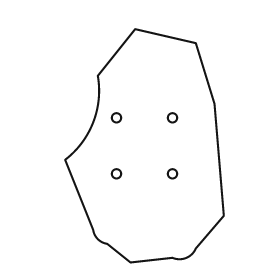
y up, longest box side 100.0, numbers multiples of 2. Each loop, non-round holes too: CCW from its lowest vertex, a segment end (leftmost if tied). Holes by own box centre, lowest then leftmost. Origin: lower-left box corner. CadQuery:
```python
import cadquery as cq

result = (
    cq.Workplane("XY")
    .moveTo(28.0, 0.0)
    .lineTo(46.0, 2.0)
    .threePointArc((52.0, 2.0), (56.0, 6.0))
    .lineTo(68.0, 20.0)
    .lineTo(64.0, 68.0)
    .lineTo(56.0, 94.0)
    .lineTo(30.0, 100.0)
    .lineTo(14.0, 80.0)
    .threePointArc((12.0, 60.0), (0.0, 44.0))
    .lineTo(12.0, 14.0)
    .threePointArc((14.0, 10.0), (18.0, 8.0))
    .close()
    .moveTo(22.0, 38.0)
    .circle(2.0)
    .moveTo(46.0, 38.0)
    .circle(2.0)
    .moveTo(22.0, 62.0)
    .circle(2.0)
    .moveTo(46.0, 62.0)
    .circle(2.0)
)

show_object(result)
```